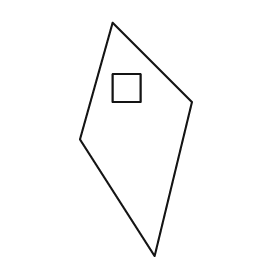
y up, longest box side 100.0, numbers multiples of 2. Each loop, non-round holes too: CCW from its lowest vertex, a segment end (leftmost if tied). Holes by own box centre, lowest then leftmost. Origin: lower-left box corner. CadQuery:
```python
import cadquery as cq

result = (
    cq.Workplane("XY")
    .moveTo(32.0, 0.0)
    .lineTo(48.0, 66.0)
    .lineTo(14.0, 100.0)
    .lineTo(0.0, 50.0)
    .close()
    .moveTo(14.0, 66.0)
    .lineTo(26.0, 66.0)
    .lineTo(26.0, 78.0)
    .lineTo(14.0, 78.0)
    .close()
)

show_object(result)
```